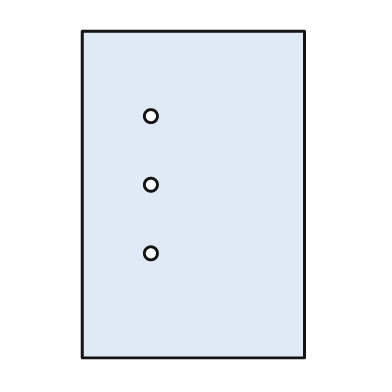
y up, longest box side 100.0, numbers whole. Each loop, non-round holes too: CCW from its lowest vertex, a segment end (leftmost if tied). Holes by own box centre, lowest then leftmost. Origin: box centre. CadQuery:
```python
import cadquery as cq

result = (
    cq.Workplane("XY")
    .moveTo(-34.0, -50.0)
    .lineTo(34.0, -50.0)
    .lineTo(34.0, 50.0)
    .lineTo(-34.0, 50.0)
    .close()
    .moveTo(-13.0, -18.0)
    .circle(2.0)
    .moveTo(-13.0, 3.0)
    .circle(2.0)
    .moveTo(-13.0, 24.0)
    .circle(2.0)
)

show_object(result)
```